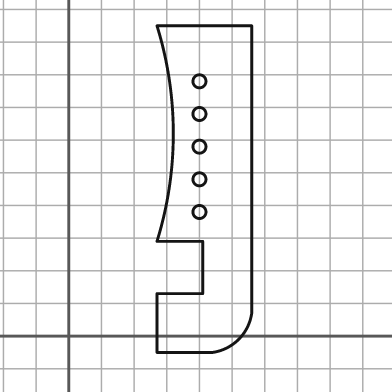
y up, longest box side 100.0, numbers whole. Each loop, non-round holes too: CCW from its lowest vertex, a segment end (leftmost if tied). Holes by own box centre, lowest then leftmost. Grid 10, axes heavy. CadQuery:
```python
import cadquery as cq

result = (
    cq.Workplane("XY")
    .moveTo(27.0, -5.0)
    .lineTo(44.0, -5.0)
    .threePointArc((52.0, -1.0), (56.0, 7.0))
    .lineTo(56.0, 95.0)
    .lineTo(27.0, 95.0)
    .threePointArc((32.0, 62.0), (27.0, 29.0))
    .lineTo(41.0, 29.0)
    .lineTo(41.0, 13.0)
    .lineTo(27.0, 13.0)
    .close()
    .moveTo(40.0, 38.0)
    .circle(2.0)
    .moveTo(40.0, 48.0)
    .circle(2.0)
    .moveTo(40.0, 58.0)
    .circle(2.0)
    .moveTo(40.0, 68.0)
    .circle(2.0)
    .moveTo(40.0, 78.0)
    .circle(2.0)
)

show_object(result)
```